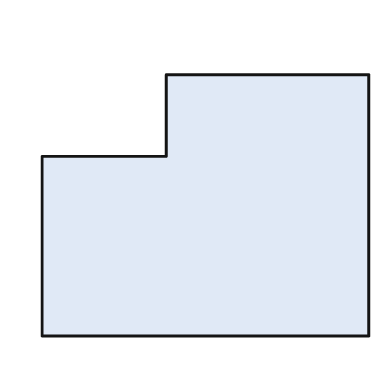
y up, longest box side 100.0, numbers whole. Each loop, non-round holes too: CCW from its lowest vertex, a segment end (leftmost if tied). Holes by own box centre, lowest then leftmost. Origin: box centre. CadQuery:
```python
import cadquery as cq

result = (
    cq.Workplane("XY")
    .moveTo(-50.0, -40.0)
    .lineTo(50.0, -40.0)
    .lineTo(50.0, 40.0)
    .lineTo(-12.0, 40.0)
    .lineTo(-12.0, 15.0)
    .lineTo(-50.0, 15.0)
    .close()
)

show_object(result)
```